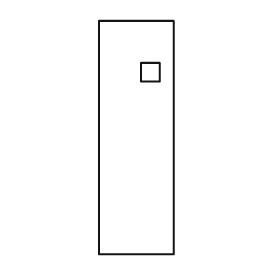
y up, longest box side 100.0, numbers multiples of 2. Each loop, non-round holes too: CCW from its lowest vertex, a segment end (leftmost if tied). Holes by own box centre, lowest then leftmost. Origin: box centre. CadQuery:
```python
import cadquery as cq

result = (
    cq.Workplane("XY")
    .moveTo(-16.0, -50.0)
    .lineTo(16.0, -50.0)
    .lineTo(16.0, 50.0)
    .lineTo(-16.0, 50.0)
    .close()
    .moveTo(2.0, 24.0)
    .lineTo(10.0, 24.0)
    .lineTo(10.0, 32.0)
    .lineTo(2.0, 32.0)
    .close()
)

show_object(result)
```